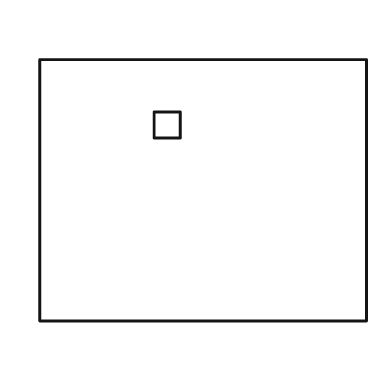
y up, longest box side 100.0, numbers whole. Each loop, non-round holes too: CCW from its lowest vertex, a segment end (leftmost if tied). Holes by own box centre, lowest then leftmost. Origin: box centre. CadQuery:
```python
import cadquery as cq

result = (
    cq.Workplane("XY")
    .moveTo(-50.0, -40.0)
    .lineTo(50.0, -40.0)
    .lineTo(50.0, 40.0)
    .lineTo(-50.0, 40.0)
    .close()
    .moveTo(-15.0, 16.0)
    .lineTo(-7.0, 16.0)
    .lineTo(-7.0, 24.0)
    .lineTo(-15.0, 24.0)
    .close()
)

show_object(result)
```